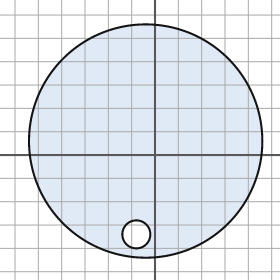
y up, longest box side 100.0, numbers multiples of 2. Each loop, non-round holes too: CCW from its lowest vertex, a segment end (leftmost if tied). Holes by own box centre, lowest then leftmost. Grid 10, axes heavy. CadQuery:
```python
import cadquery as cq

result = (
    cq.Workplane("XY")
    .moveTo(-4.0, 6.0)
    .circle(50.0)
    .moveTo(-8.0, -34.0)
    .circle(6.0)
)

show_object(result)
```